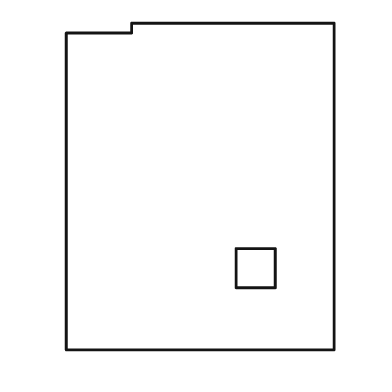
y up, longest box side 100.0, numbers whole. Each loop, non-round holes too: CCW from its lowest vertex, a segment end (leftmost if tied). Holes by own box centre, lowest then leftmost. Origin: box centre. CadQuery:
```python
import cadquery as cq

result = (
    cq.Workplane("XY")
    .moveTo(-41.0, -50.0)
    .lineTo(41.0, -50.0)
    .lineTo(41.0, 50.0)
    .lineTo(-21.0, 50.0)
    .lineTo(-21.0, 47.0)
    .lineTo(-41.0, 47.0)
    .close()
    .moveTo(11.0, -31.0)
    .lineTo(23.0, -31.0)
    .lineTo(23.0, -19.0)
    .lineTo(11.0, -19.0)
    .close()
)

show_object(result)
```